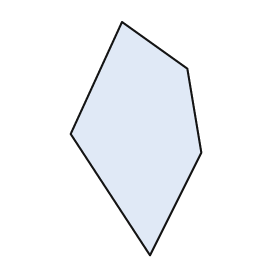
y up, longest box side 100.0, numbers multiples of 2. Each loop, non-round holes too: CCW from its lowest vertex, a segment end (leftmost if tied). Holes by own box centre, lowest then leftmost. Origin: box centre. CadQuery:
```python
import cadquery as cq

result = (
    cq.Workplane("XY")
    .moveTo(6.0, -50.0)
    .lineTo(28.0, -6.0)
    .lineTo(22.0, 30.0)
    .lineTo(-6.0, 50.0)
    .lineTo(-28.0, 2.0)
    .close()
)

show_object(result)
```